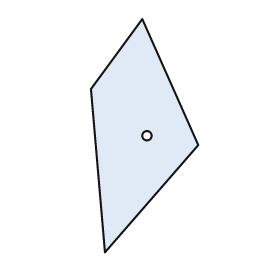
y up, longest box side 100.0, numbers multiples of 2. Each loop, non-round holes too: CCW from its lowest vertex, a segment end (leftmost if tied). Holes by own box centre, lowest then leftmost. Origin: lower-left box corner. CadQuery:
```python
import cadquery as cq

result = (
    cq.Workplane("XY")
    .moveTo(6.0, 0.0)
    .lineTo(46.0, 46.0)
    .lineTo(22.0, 100.0)
    .lineTo(0.0, 70.0)
    .close()
    .moveTo(24.0, 50.0)
    .circle(2.0)
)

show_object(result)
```